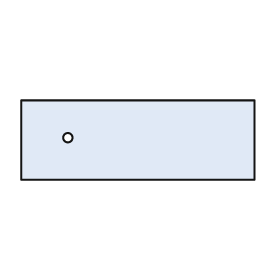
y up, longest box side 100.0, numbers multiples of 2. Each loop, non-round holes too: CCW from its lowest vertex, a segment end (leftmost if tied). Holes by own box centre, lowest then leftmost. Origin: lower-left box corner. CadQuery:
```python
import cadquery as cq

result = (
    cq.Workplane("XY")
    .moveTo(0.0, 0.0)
    .lineTo(100.0, 0.0)
    .lineTo(100.0, 34.0)
    .lineTo(0.0, 34.0)
    .close()
    .moveTo(20.0, 18.0)
    .circle(2.0)
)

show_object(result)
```